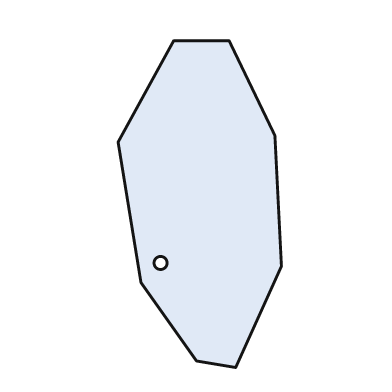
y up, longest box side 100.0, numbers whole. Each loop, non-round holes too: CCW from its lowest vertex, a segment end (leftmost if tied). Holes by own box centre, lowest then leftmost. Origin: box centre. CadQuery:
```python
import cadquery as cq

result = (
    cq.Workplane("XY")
    .moveTo(11.0, -50.0)
    .lineTo(25.0, -19.0)
    .lineTo(23.0, 21.0)
    .lineTo(9.0, 50.0)
    .lineTo(-8.0, 50.0)
    .lineTo(-25.0, 19.0)
    .lineTo(-18.0, -24.0)
    .lineTo(-1.0, -48.0)
    .close()
    .moveTo(-12.0, -18.0)
    .circle(2.0)
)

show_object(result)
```